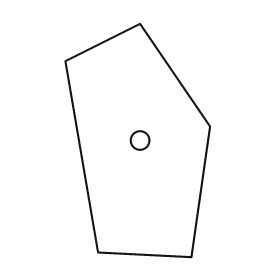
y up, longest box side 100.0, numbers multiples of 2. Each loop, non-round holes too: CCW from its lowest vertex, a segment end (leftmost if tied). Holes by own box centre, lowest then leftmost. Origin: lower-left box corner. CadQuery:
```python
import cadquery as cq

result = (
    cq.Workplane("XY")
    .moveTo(54.0, 0.0)
    .lineTo(62.0, 56.0)
    .lineTo(32.0, 100.0)
    .lineTo(0.0, 84.0)
    .lineTo(14.0, 2.0)
    .close()
    .moveTo(32.0, 50.0)
    .circle(4.0)
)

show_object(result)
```